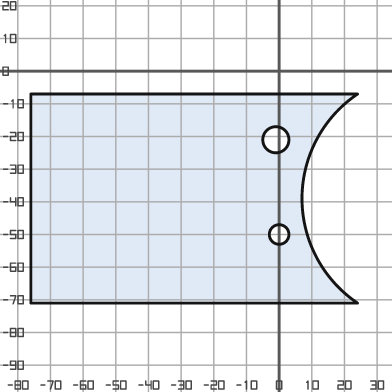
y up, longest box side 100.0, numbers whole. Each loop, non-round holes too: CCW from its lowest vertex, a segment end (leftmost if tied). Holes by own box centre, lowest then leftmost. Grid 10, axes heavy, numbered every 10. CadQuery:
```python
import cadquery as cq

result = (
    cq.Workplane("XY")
    .moveTo(-76.0, -71.0)
    .lineTo(24.0, -71.0)
    .threePointArc((7.0, -39.0), (24.0, -7.0))
    .lineTo(-76.0, -7.0)
    .close()
    .moveTo(0.0, -50.0)
    .circle(3.0)
    .moveTo(-1.0, -21.0)
    .circle(4.0)
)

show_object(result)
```